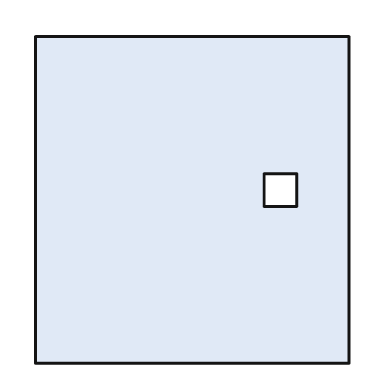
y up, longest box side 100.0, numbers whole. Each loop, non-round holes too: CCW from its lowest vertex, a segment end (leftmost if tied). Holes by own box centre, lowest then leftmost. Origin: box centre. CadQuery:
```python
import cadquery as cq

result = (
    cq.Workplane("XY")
    .moveTo(-48.0, -50.0)
    .lineTo(48.0, -50.0)
    .lineTo(48.0, 50.0)
    .lineTo(-48.0, 50.0)
    .close()
    .moveTo(22.0, -2.0)
    .lineTo(32.0, -2.0)
    .lineTo(32.0, 8.0)
    .lineTo(22.0, 8.0)
    .close()
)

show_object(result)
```